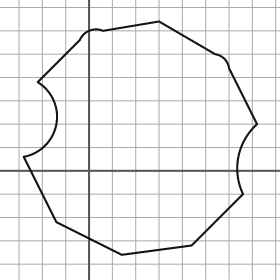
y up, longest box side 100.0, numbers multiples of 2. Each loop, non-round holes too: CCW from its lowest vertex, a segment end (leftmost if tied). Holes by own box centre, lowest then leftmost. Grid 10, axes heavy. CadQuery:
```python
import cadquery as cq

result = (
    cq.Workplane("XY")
    .moveTo(14.0, -36.0)
    .lineTo(44.0, -32.0)
    .lineTo(66.0, -10.0)
    .threePointArc((64.0, 6.0), (72.0, 20.0))
    .lineTo(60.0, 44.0)
    .threePointArc((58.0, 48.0), (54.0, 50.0))
    .lineTo(30.0, 64.0)
    .lineTo(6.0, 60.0)
    .threePointArc((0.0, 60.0), (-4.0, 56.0))
    .lineTo(-22.0, 38.0)
    .threePointArc((-14.0, 20.0), (-28.0, 6.0))
    .lineTo(-14.0, -22.0)
    .close()
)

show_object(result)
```